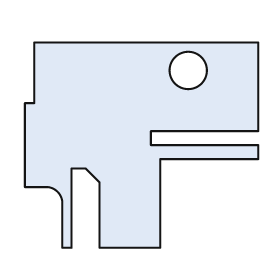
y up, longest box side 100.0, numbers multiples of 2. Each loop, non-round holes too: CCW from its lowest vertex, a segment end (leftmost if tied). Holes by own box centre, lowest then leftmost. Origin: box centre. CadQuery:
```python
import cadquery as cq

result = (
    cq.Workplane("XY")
    .moveTo(-34.0, -44.0)
    .lineTo(-30.0, -44.0)
    .lineTo(-30.0, -10.0)
    .lineTo(-24.0, -10.0)
    .lineTo(-18.0, -16.0)
    .lineTo(-18.0, -44.0)
    .lineTo(8.0, -44.0)
    .lineTo(8.0, -6.0)
    .lineTo(50.0, -6.0)
    .lineTo(50.0, 0.0)
    .lineTo(4.0, 0.0)
    .lineTo(4.0, 6.0)
    .lineTo(50.0, 6.0)
    .lineTo(50.0, 44.0)
    .lineTo(-46.0, 44.0)
    .lineTo(-46.0, 18.0)
    .lineTo(-50.0, 18.0)
    .lineTo(-50.0, -18.0)
    .lineTo(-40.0, -18.0)
    .threePointArc((-36.0, -20.0), (-34.0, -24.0))
    .close()
    .moveTo(20.0, 32.0)
    .circle(8.0)
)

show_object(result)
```